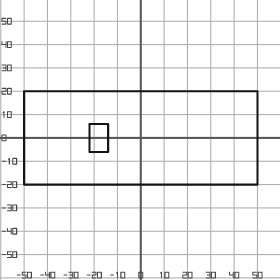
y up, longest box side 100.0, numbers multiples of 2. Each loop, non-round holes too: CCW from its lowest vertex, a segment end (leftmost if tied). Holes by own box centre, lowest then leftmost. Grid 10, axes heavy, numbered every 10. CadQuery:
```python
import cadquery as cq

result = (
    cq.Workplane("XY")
    .moveTo(-50.0, -20.0)
    .lineTo(50.0, -20.0)
    .lineTo(50.0, 20.0)
    .lineTo(-50.0, 20.0)
    .close()
    .moveTo(-22.0, -6.0)
    .lineTo(-14.0, -6.0)
    .lineTo(-14.0, 6.0)
    .lineTo(-22.0, 6.0)
    .close()
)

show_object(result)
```